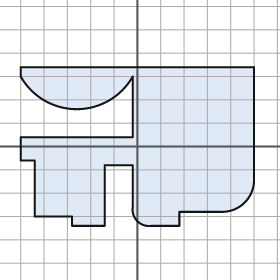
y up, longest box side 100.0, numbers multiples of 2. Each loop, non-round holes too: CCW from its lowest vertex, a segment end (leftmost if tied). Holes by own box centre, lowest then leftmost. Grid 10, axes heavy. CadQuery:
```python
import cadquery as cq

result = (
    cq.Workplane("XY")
    .moveTo(-28.0, -34.0)
    .lineTo(-14.0, -34.0)
    .lineTo(-14.0, -8.0)
    .lineTo(-2.0, -8.0)
    .lineTo(-2.0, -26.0)
    .threePointArc((0.0, -32.0), (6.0, -34.0))
    .lineTo(18.0, -34.0)
    .lineTo(18.0, -28.0)
    .lineTo(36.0, -28.0)
    .threePointArc((46.0, -24.0), (50.0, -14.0))
    .lineTo(50.0, 34.0)
    .lineTo(-50.0, 34.0)
    .lineTo(-50.0, 30.0)
    .threePointArc((-26.0, 16.0), (-2.0, 30.0))
    .lineTo(-2.0, 4.0)
    .lineTo(-50.0, 4.0)
    .lineTo(-50.0, -6.0)
    .lineTo(-44.0, -6.0)
    .lineTo(-44.0, -30.0)
    .lineTo(-28.0, -30.0)
    .close()
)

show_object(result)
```